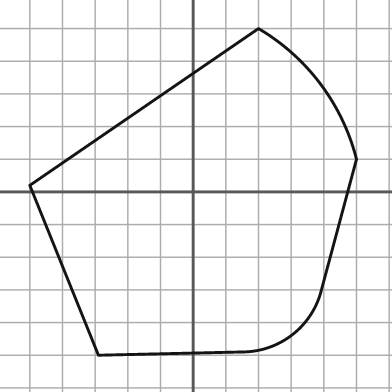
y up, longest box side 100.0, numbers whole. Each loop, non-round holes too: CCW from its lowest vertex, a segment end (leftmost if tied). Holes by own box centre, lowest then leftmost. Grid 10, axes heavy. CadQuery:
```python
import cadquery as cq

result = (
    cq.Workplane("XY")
    .moveTo(-29.0, -50.0)
    .lineTo(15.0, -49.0)
    .threePointArc((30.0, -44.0), (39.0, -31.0))
    .lineTo(50.0, 10.0)
    .threePointArc((39.0, 33.0), (20.0, 50.0))
    .lineTo(-50.0, 2.0)
    .close()
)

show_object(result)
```